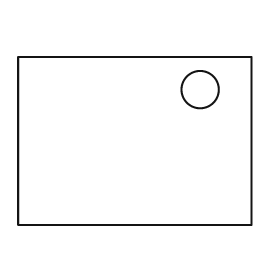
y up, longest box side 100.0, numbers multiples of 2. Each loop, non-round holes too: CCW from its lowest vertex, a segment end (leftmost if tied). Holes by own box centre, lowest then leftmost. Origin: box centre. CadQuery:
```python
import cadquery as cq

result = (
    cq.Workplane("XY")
    .moveTo(-50.0, -36.0)
    .lineTo(50.0, -36.0)
    .lineTo(50.0, 36.0)
    .lineTo(-50.0, 36.0)
    .close()
    .moveTo(28.0, 22.0)
    .circle(8.0)
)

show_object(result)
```